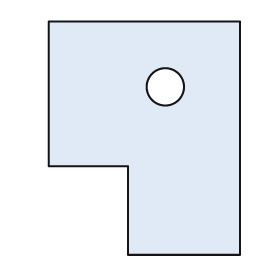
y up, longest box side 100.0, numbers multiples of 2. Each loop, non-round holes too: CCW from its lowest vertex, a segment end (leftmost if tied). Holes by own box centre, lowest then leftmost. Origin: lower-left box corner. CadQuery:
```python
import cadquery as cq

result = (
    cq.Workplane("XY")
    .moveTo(34.0, 0.0)
    .lineTo(82.0, 0.0)
    .lineTo(82.0, 100.0)
    .lineTo(0.0, 100.0)
    .lineTo(0.0, 38.0)
    .lineTo(34.0, 38.0)
    .close()
    .moveTo(50.0, 72.0)
    .circle(8.0)
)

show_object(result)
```